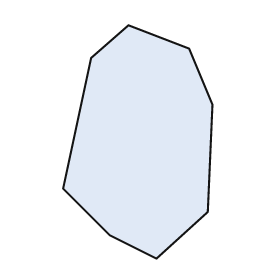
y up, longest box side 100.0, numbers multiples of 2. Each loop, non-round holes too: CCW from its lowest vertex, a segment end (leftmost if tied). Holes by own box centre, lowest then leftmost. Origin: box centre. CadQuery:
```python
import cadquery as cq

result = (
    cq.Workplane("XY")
    .moveTo(8.0, -50.0)
    .lineTo(30.0, -30.0)
    .lineTo(32.0, 16.0)
    .lineTo(22.0, 40.0)
    .lineTo(-4.0, 50.0)
    .lineTo(-20.0, 36.0)
    .lineTo(-32.0, -20.0)
    .lineTo(-12.0, -40.0)
    .close()
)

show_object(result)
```